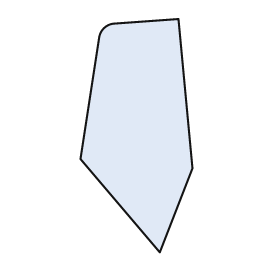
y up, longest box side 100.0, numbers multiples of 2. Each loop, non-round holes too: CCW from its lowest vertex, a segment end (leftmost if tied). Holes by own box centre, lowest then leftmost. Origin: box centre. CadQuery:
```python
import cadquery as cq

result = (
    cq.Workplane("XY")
    .moveTo(10.0, -50.0)
    .lineTo(24.0, -14.0)
    .lineTo(18.0, 50.0)
    .lineTo(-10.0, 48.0)
    .threePointArc((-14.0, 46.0), (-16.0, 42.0))
    .lineTo(-24.0, -10.0)
    .close()
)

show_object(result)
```